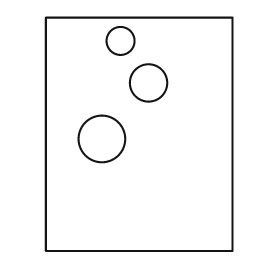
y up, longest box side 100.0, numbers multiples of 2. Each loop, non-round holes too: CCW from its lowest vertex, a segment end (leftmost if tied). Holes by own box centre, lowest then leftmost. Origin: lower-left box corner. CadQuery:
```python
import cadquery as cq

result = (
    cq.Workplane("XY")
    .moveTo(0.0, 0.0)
    .lineTo(80.0, 0.0)
    .lineTo(80.0, 100.0)
    .lineTo(0.0, 100.0)
    .close()
    .moveTo(24.0, 48.0)
    .circle(10.0)
    .moveTo(44.0, 72.0)
    .circle(8.0)
    .moveTo(32.0, 90.0)
    .circle(6.0)
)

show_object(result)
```